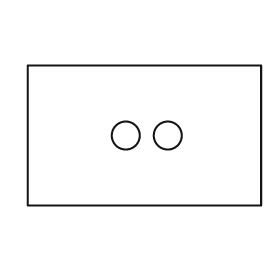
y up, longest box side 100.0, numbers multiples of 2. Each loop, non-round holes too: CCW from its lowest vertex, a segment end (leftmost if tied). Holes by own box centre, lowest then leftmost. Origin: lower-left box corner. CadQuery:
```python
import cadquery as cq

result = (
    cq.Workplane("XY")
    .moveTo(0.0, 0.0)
    .lineTo(100.0, 0.0)
    .lineTo(100.0, 60.0)
    .lineTo(0.0, 60.0)
    .close()
    .moveTo(42.0, 30.0)
    .circle(6.0)
    .moveTo(60.0, 30.0)
    .circle(6.0)
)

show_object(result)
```